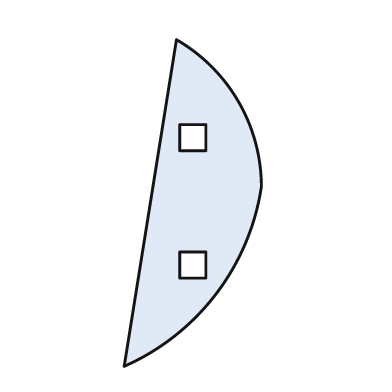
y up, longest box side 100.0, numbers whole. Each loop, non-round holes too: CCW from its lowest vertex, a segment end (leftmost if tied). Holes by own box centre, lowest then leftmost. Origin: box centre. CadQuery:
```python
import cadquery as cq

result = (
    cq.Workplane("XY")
    .moveTo(-21.0, -50.0)
    .threePointArc((7.0, -28.0), (21.0, 5.0))
    .threePointArc((14.0, 31.0), (-5.0, 50.0))
    .close()
    .moveTo(-4.0, -23.0)
    .lineTo(4.0, -23.0)
    .lineTo(4.0, -15.0)
    .lineTo(-4.0, -15.0)
    .close()
    .moveTo(-4.0, 16.0)
    .lineTo(4.0, 16.0)
    .lineTo(4.0, 24.0)
    .lineTo(-4.0, 24.0)
    .close()
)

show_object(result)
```